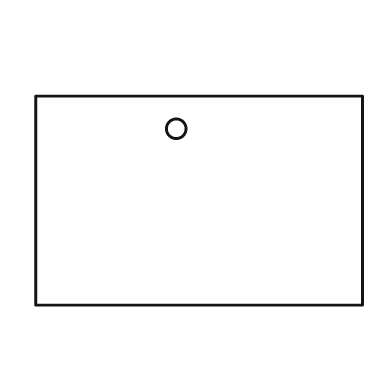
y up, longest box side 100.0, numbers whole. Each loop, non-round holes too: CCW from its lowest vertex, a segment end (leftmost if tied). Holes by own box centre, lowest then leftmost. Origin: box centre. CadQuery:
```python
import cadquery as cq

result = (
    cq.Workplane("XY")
    .moveTo(-50.0, -32.0)
    .lineTo(50.0, -32.0)
    .lineTo(50.0, 32.0)
    .lineTo(-50.0, 32.0)
    .close()
    .moveTo(-7.0, 22.0)
    .circle(3.0)
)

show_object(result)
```